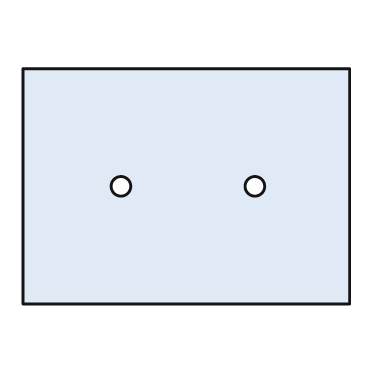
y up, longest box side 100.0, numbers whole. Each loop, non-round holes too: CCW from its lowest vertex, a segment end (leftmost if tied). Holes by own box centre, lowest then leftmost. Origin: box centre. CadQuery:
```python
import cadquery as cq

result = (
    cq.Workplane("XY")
    .moveTo(-50.0, -36.0)
    .lineTo(50.0, -36.0)
    .lineTo(50.0, 36.0)
    .lineTo(-50.0, 36.0)
    .close()
    .moveTo(-20.0, 0.0)
    .circle(3.0)
    .moveTo(21.0, 0.0)
    .circle(3.0)
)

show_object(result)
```